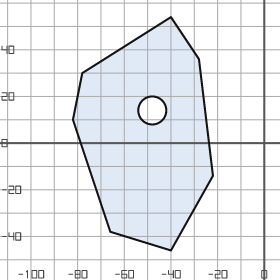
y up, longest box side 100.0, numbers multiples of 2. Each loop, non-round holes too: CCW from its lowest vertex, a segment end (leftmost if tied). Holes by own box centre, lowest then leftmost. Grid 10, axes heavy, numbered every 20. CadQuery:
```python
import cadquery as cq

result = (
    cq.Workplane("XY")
    .moveTo(-40.0, -46.0)
    .lineTo(-22.0, -14.0)
    .lineTo(-28.0, 36.0)
    .lineTo(-40.0, 54.0)
    .lineTo(-78.0, 30.0)
    .lineTo(-82.0, 10.0)
    .lineTo(-66.0, -38.0)
    .close()
    .moveTo(-48.0, 14.0)
    .circle(6.0)
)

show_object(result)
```